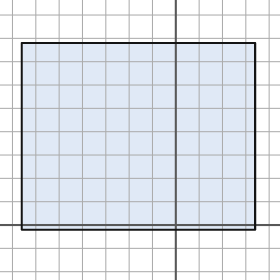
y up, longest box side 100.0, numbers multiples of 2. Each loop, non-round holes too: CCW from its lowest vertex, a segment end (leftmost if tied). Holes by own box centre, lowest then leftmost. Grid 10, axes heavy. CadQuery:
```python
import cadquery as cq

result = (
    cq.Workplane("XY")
    .moveTo(-66.0, -2.0)
    .lineTo(34.0, -2.0)
    .lineTo(34.0, 78.0)
    .lineTo(-66.0, 78.0)
    .close()
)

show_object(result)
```